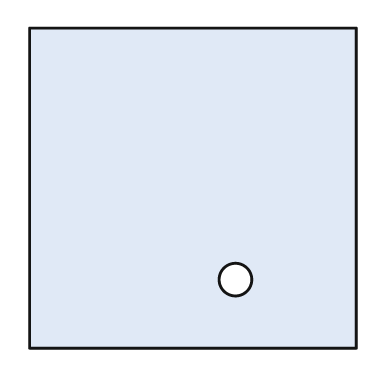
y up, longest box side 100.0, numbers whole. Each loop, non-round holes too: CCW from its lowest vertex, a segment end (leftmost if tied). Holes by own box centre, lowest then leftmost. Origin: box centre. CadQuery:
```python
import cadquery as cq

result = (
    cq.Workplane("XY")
    .moveTo(-50.0, -49.0)
    .lineTo(50.0, -49.0)
    .lineTo(50.0, 49.0)
    .lineTo(-50.0, 49.0)
    .close()
    .moveTo(13.0, -28.0)
    .circle(5.0)
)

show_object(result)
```